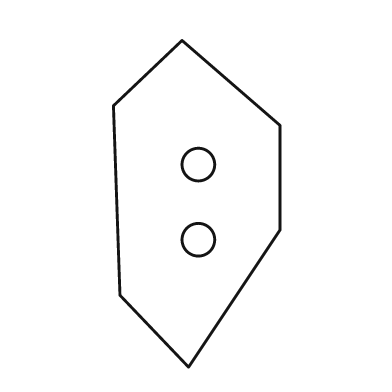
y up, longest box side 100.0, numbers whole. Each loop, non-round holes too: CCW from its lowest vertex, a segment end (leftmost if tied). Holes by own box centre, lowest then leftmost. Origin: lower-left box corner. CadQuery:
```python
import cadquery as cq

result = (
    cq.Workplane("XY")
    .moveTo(23.0, 0.0)
    .lineTo(51.0, 42.0)
    .lineTo(51.0, 74.0)
    .lineTo(21.0, 100.0)
    .lineTo(0.0, 80.0)
    .lineTo(2.0, 22.0)
    .close()
    .moveTo(26.0, 39.0)
    .circle(5.0)
    .moveTo(26.0, 62.0)
    .circle(5.0)
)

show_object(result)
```